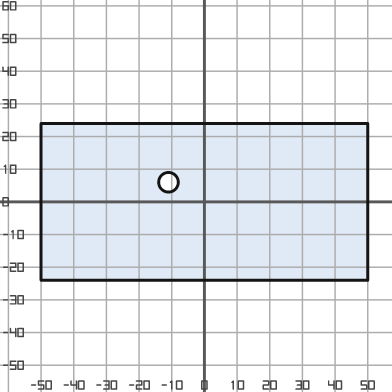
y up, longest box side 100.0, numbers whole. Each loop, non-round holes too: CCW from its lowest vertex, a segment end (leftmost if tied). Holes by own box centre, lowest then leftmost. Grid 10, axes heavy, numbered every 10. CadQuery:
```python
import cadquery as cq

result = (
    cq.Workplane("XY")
    .moveTo(-50.0, -24.0)
    .lineTo(50.0, -24.0)
    .lineTo(50.0, 24.0)
    .lineTo(-50.0, 24.0)
    .close()
    .moveTo(-11.0, 6.0)
    .circle(3.0)
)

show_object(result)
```